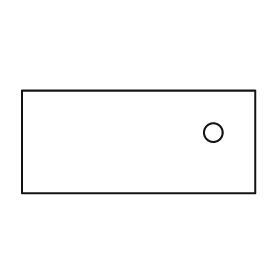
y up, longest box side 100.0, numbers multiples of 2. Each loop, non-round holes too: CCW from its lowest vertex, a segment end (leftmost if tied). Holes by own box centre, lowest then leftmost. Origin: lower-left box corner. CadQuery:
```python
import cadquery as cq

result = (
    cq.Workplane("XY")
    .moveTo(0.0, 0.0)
    .lineTo(100.0, 0.0)
    .lineTo(100.0, 44.0)
    .lineTo(0.0, 44.0)
    .close()
    .moveTo(82.0, 26.0)
    .circle(4.0)
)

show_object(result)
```